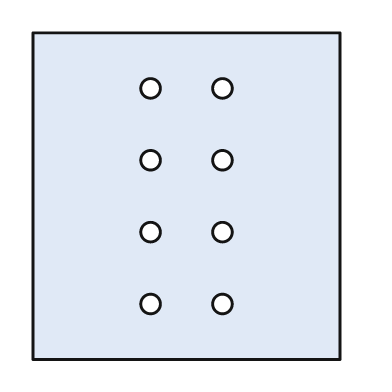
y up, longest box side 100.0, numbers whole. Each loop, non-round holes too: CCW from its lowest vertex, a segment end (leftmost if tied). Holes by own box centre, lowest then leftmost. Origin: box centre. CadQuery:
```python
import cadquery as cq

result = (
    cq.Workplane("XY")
    .moveTo(-47.0, -50.0)
    .lineTo(47.0, -50.0)
    .lineTo(47.0, 50.0)
    .lineTo(-47.0, 50.0)
    .close()
    .moveTo(-11.0, -33.0)
    .circle(3.0)
    .moveTo(11.0, -33.0)
    .circle(3.0)
    .moveTo(-11.0, -11.0)
    .circle(3.0)
    .moveTo(11.0, -11.0)
    .circle(3.0)
    .moveTo(-11.0, 11.0)
    .circle(3.0)
    .moveTo(11.0, 11.0)
    .circle(3.0)
    .moveTo(-11.0, 33.0)
    .circle(3.0)
    .moveTo(11.0, 33.0)
    .circle(3.0)
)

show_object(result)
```